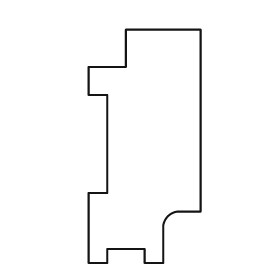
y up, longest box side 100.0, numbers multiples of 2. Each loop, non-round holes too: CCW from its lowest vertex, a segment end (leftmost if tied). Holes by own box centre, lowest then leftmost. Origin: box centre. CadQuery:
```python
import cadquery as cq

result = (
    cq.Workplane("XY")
    .moveTo(-24.0, -50.0)
    .lineTo(-16.0, -50.0)
    .lineTo(-16.0, -44.0)
    .lineTo(0.0, -44.0)
    .lineTo(0.0, -50.0)
    .lineTo(8.0, -50.0)
    .lineTo(8.0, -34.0)
    .threePointArc((10.0, -30.0), (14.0, -28.0))
    .lineTo(24.0, -28.0)
    .lineTo(24.0, 50.0)
    .lineTo(-8.0, 50.0)
    .lineTo(-8.0, 34.0)
    .lineTo(-24.0, 34.0)
    .lineTo(-24.0, 22.0)
    .lineTo(-16.0, 22.0)
    .lineTo(-16.0, -20.0)
    .lineTo(-24.0, -20.0)
    .close()
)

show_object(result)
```